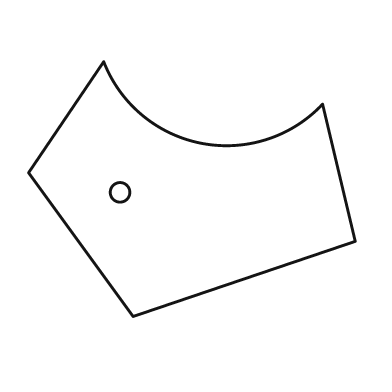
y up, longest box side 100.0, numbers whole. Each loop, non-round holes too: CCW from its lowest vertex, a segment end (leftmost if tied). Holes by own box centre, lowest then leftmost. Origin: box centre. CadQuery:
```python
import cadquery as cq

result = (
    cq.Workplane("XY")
    .moveTo(-18.0, -39.0)
    .lineTo(50.0, -16.0)
    .lineTo(40.0, 26.0)
    .threePointArc((3.0, 14.0), (-27.0, 39.0))
    .lineTo(-50.0, 5.0)
    .close()
    .moveTo(-22.0, -1.0)
    .circle(3.0)
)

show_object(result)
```